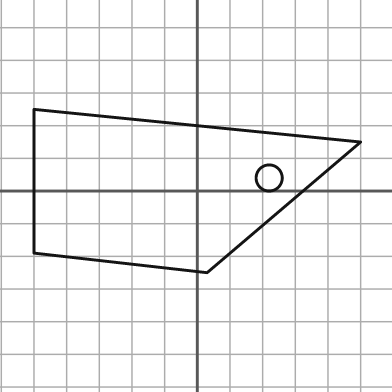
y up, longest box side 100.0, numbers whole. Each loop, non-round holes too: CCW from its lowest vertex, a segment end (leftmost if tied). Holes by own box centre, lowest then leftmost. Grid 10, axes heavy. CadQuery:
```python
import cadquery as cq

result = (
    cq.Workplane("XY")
    .moveTo(3.0, -25.0)
    .lineTo(50.0, 15.0)
    .lineTo(-50.0, 25.0)
    .lineTo(-50.0, -19.0)
    .close()
    .moveTo(22.0, 4.0)
    .circle(4.0)
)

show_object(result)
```